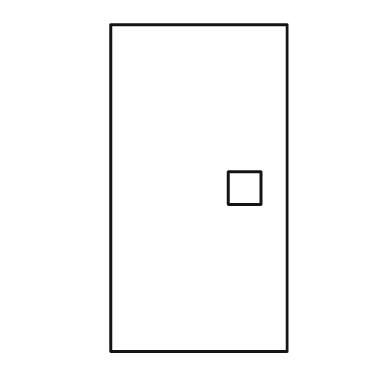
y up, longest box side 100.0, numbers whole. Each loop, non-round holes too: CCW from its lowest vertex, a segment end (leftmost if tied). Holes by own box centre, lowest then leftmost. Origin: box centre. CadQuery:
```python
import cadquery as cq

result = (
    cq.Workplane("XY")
    .moveTo(-27.0, -50.0)
    .lineTo(27.0, -50.0)
    .lineTo(27.0, 50.0)
    .lineTo(-27.0, 50.0)
    .close()
    .moveTo(9.0, -5.0)
    .lineTo(19.0, -5.0)
    .lineTo(19.0, 5.0)
    .lineTo(9.0, 5.0)
    .close()
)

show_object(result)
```